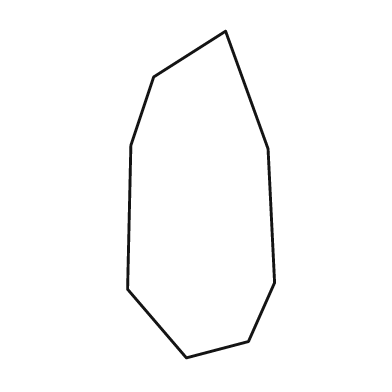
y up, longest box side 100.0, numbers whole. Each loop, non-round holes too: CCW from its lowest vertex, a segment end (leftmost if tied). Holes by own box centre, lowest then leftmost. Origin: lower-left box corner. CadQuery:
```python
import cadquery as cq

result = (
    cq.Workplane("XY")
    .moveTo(18.0, 0.0)
    .lineTo(37.0, 5.0)
    .lineTo(45.0, 23.0)
    .lineTo(43.0, 64.0)
    .lineTo(30.0, 100.0)
    .lineTo(8.0, 86.0)
    .lineTo(1.0, 65.0)
    .lineTo(0.0, 21.0)
    .close()
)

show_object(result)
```